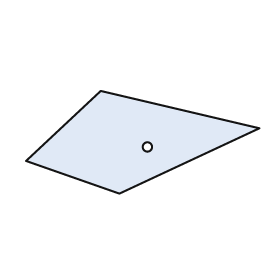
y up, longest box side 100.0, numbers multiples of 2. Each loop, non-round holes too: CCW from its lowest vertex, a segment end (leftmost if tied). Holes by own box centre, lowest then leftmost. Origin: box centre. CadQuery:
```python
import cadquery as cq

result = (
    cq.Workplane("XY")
    .moveTo(-10.0, -22.0)
    .lineTo(50.0, 6.0)
    .lineTo(-18.0, 22.0)
    .lineTo(-50.0, -8.0)
    .close()
    .moveTo(2.0, -2.0)
    .circle(2.0)
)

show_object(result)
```